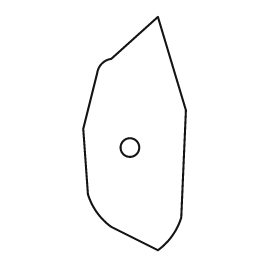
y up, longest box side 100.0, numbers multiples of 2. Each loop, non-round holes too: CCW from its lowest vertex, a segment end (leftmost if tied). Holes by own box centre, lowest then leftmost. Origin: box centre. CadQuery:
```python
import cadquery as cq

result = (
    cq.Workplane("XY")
    .moveTo(10.0, -50.0)
    .threePointArc((16.0, -44.0), (20.0, -36.0))
    .lineTo(22.0, 10.0)
    .lineTo(10.0, 50.0)
    .lineTo(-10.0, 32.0)
    .threePointArc((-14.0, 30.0), (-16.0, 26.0))
    .lineTo(-22.0, 2.0)
    .lineTo(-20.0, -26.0)
    .threePointArc((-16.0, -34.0), (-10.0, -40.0))
    .close()
    .moveTo(-2.0, -6.0)
    .circle(4.0)
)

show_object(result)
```